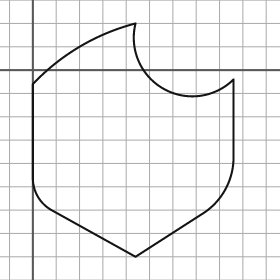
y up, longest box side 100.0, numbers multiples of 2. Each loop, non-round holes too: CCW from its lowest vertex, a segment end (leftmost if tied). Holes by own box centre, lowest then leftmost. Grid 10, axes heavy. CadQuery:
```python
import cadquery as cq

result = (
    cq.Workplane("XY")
    .moveTo(44.0, -80.0)
    .lineTo(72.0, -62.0)
    .threePointArc((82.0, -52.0), (86.0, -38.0))
    .lineTo(86.0, -4.0)
    .threePointArc((56.0, -8.0), (44.0, 20.0))
    .threePointArc((20.0, 10.0), (0.0, -6.0))
    .lineTo(0.0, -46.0)
    .threePointArc((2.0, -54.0), (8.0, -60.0))
    .close()
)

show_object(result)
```